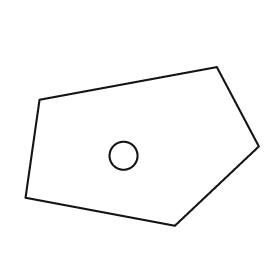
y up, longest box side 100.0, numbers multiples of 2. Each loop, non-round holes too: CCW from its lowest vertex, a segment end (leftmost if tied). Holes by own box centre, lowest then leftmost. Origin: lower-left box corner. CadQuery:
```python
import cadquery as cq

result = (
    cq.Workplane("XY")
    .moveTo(64.0, 0.0)
    .lineTo(100.0, 34.0)
    .lineTo(82.0, 68.0)
    .lineTo(6.0, 54.0)
    .lineTo(0.0, 12.0)
    .close()
    .moveTo(42.0, 30.0)
    .circle(6.0)
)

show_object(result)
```